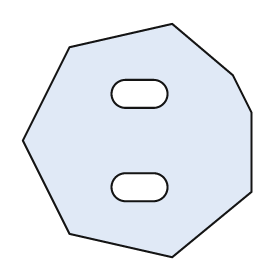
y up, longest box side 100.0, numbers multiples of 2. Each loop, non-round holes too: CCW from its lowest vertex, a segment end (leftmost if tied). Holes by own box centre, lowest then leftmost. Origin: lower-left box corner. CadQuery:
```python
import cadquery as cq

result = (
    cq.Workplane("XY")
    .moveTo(64.0, 0.0)
    .lineTo(98.0, 28.0)
    .lineTo(98.0, 62.0)
    .lineTo(90.0, 78.0)
    .lineTo(64.0, 100.0)
    .lineTo(20.0, 90.0)
    .lineTo(0.0, 50.0)
    .lineTo(20.0, 10.0)
    .close()
    .moveTo(44.0, 24.0)
    .lineTo(56.0, 24.0)
    .threePointArc((62.0, 30.0), (56.0, 36.0))
    .lineTo(44.0, 36.0)
    .threePointArc((38.0, 30.0), (44.0, 24.0))
    .close()
    .moveTo(44.0, 64.0)
    .lineTo(56.0, 64.0)
    .threePointArc((62.0, 70.0), (56.0, 76.0))
    .lineTo(44.0, 76.0)
    .threePointArc((38.0, 70.0), (44.0, 64.0))
    .close()
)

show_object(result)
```